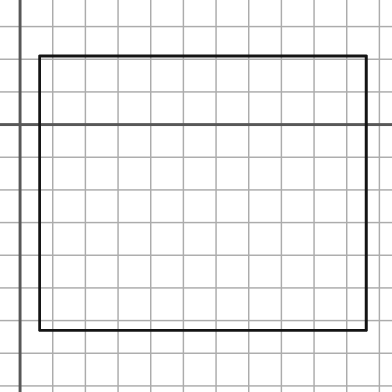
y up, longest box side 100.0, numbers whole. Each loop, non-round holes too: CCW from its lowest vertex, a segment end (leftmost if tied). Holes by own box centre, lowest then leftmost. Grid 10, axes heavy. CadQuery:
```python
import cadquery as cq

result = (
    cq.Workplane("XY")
    .moveTo(6.0, -63.0)
    .lineTo(106.0, -63.0)
    .lineTo(106.0, 21.0)
    .lineTo(6.0, 21.0)
    .close()
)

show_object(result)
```